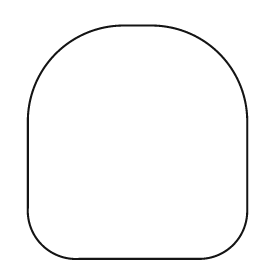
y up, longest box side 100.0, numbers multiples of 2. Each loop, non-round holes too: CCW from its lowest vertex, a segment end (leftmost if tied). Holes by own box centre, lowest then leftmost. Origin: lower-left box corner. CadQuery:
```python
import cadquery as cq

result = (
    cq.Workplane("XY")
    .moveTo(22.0, 0.0)
    .lineTo(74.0, 0.0)
    .threePointArc((88.0, 6.0), (94.0, 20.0))
    .lineTo(94.0, 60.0)
    .threePointArc((82.0, 88.0), (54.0, 100.0))
    .lineTo(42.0, 100.0)
    .threePointArc((12.0, 88.0), (0.0, 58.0))
    .lineTo(0.0, 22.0)
    .threePointArc((6.0, 6.0), (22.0, 0.0))
    .close()
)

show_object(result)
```